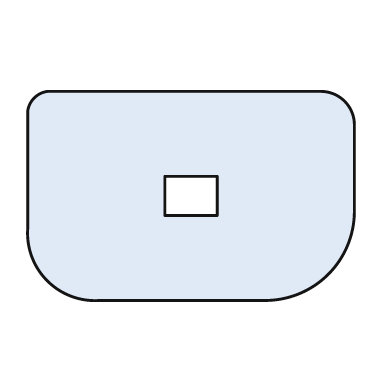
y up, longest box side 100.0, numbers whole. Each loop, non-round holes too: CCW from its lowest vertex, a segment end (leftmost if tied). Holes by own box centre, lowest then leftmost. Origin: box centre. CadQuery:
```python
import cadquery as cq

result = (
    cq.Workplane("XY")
    .moveTo(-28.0, -32.0)
    .lineTo(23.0, -32.0)
    .threePointArc((42.0, -24.0), (50.0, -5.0))
    .lineTo(50.0, 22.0)
    .threePointArc((47.0, 29.0), (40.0, 32.0))
    .lineTo(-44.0, 32.0)
    .threePointArc((-48.0, 30.0), (-50.0, 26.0))
    .lineTo(-50.0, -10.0)
    .threePointArc((-44.0, -26.0), (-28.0, -32.0))
    .close()
    .moveTo(-8.0, -6.0)
    .lineTo(8.0, -6.0)
    .lineTo(8.0, 6.0)
    .lineTo(-8.0, 6.0)
    .close()
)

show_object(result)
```